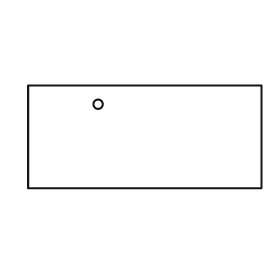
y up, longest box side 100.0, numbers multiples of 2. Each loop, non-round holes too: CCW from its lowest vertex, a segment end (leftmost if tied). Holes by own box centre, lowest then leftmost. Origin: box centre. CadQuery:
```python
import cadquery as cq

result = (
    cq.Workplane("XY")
    .moveTo(-50.0, -22.0)
    .lineTo(50.0, -22.0)
    .lineTo(50.0, 22.0)
    .lineTo(-50.0, 22.0)
    .close()
    .moveTo(-20.0, 14.0)
    .circle(2.0)
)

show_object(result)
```